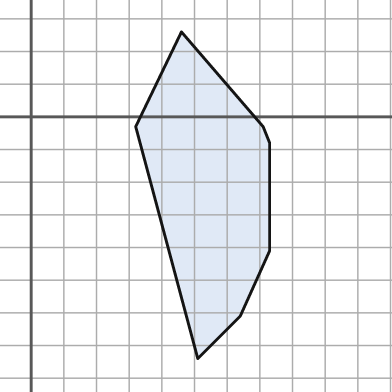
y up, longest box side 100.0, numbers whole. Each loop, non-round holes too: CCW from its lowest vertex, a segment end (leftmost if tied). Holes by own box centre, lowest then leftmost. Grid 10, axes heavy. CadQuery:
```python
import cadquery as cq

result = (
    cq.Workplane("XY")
    .moveTo(51.0, -74.0)
    .lineTo(64.0, -61.0)
    .lineTo(73.0, -41.0)
    .lineTo(73.0, -8.0)
    .lineTo(71.0, -3.0)
    .lineTo(46.0, 26.0)
    .lineTo(32.0, -3.0)
    .close()
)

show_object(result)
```